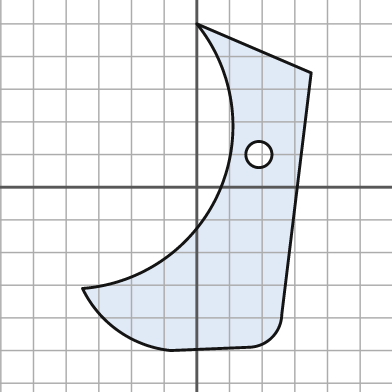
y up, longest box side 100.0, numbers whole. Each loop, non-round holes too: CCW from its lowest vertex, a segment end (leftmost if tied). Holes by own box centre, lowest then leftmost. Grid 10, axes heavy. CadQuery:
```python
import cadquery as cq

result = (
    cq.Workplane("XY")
    .moveTo(-8.0, -50.0)
    .lineTo(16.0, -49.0)
    .threePointArc((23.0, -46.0), (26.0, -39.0))
    .lineTo(35.0, 35.0)
    .lineTo(0.0, 50.0)
    .threePointArc((7.0, -1.0), (-35.0, -31.0))
    .threePointArc((-24.0, -44.0), (-8.0, -50.0))
    .close()
    .moveTo(19.0, 10.0)
    .circle(4.0)
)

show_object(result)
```